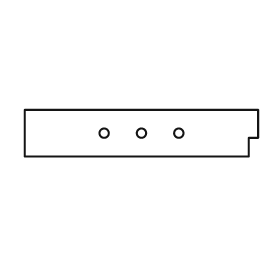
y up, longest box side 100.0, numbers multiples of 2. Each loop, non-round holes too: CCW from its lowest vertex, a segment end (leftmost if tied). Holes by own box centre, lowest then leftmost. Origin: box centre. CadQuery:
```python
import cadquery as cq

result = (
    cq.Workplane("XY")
    .moveTo(-50.0, -10.0)
    .lineTo(46.0, -10.0)
    .lineTo(46.0, -2.0)
    .lineTo(50.0, -2.0)
    .lineTo(50.0, 10.0)
    .lineTo(-50.0, 10.0)
    .close()
    .moveTo(-16.0, 0.0)
    .circle(2.0)
    .moveTo(0.0, 0.0)
    .circle(2.0)
    .moveTo(16.0, 0.0)
    .circle(2.0)
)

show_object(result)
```